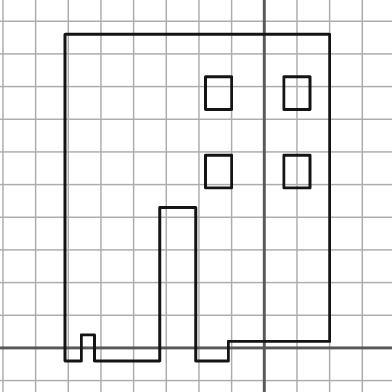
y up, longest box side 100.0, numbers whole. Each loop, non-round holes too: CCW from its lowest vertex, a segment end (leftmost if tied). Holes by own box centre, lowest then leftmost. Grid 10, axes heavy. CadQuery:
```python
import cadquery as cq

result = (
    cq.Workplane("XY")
    .moveTo(-61.0, -4.0)
    .lineTo(-56.0, -4.0)
    .lineTo(-56.0, 4.0)
    .lineTo(-52.0, 4.0)
    .lineTo(-52.0, -4.0)
    .lineTo(-32.0, -4.0)
    .lineTo(-32.0, 43.0)
    .lineTo(-21.0, 43.0)
    .lineTo(-21.0, -4.0)
    .lineTo(-11.0, -4.0)
    .lineTo(-11.0, 2.0)
    .lineTo(20.0, 2.0)
    .lineTo(20.0, 96.0)
    .lineTo(-61.0, 96.0)
    .close()
    .moveTo(-18.0, 49.0)
    .lineTo(-10.0, 49.0)
    .lineTo(-10.0, 59.0)
    .lineTo(-18.0, 59.0)
    .close()
    .moveTo(6.0, 49.0)
    .lineTo(14.0, 49.0)
    .lineTo(14.0, 59.0)
    .lineTo(6.0, 59.0)
    .close()
    .moveTo(-18.0, 73.0)
    .lineTo(-10.0, 73.0)
    .lineTo(-10.0, 83.0)
    .lineTo(-18.0, 83.0)
    .close()
    .moveTo(6.0, 73.0)
    .lineTo(14.0, 73.0)
    .lineTo(14.0, 83.0)
    .lineTo(6.0, 83.0)
    .close()
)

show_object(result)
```